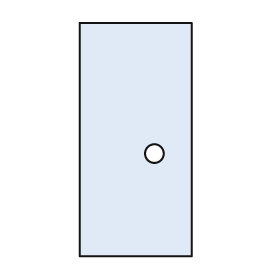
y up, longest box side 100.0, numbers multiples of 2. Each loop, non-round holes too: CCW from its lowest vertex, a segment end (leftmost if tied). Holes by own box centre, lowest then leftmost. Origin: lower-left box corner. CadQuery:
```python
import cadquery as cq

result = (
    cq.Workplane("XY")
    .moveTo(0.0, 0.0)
    .lineTo(48.0, 0.0)
    .lineTo(48.0, 100.0)
    .lineTo(0.0, 100.0)
    .close()
    .moveTo(32.0, 44.0)
    .circle(4.0)
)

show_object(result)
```